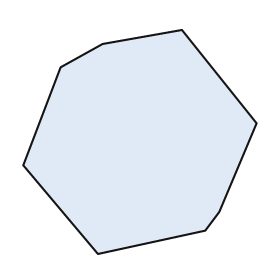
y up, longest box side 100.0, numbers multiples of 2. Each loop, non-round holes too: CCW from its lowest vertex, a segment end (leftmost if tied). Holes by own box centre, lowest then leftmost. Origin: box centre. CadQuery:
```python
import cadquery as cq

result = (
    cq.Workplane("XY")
    .moveTo(-18.0, -48.0)
    .lineTo(28.0, -38.0)
    .lineTo(34.0, -30.0)
    .lineTo(50.0, 8.0)
    .lineTo(18.0, 48.0)
    .lineTo(-16.0, 42.0)
    .lineTo(-34.0, 32.0)
    .lineTo(-50.0, -10.0)
    .close()
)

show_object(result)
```